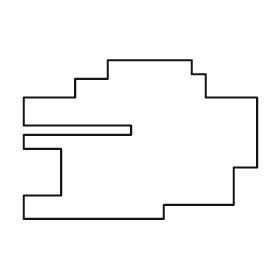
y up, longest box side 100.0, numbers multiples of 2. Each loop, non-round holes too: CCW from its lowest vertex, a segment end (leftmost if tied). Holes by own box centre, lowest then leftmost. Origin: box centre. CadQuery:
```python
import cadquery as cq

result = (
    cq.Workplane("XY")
    .moveTo(-50.0, -34.0)
    .lineTo(10.0, -34.0)
    .lineTo(10.0, -28.0)
    .lineTo(40.0, -28.0)
    .lineTo(40.0, -12.0)
    .lineTo(50.0, -12.0)
    .lineTo(50.0, 18.0)
    .lineTo(28.0, 18.0)
    .lineTo(28.0, 28.0)
    .lineTo(22.0, 28.0)
    .lineTo(22.0, 34.0)
    .lineTo(-14.0, 34.0)
    .lineTo(-14.0, 26.0)
    .lineTo(-28.0, 26.0)
    .lineTo(-28.0, 18.0)
    .lineTo(-50.0, 18.0)
    .lineTo(-50.0, 6.0)
    .lineTo(-4.0, 6.0)
    .lineTo(-4.0, 2.0)
    .lineTo(-50.0, 2.0)
    .lineTo(-50.0, -4.0)
    .lineTo(-34.0, -4.0)
    .lineTo(-34.0, -24.0)
    .lineTo(-50.0, -24.0)
    .close()
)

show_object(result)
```